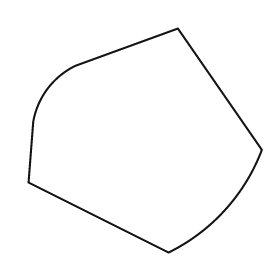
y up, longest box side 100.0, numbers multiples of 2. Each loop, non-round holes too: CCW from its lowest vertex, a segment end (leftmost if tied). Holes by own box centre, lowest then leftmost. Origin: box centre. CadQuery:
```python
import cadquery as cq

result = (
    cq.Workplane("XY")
    .moveTo(10.0, -48.0)
    .threePointArc((34.0, -30.0), (50.0, -4.0))
    .lineTo(14.0, 48.0)
    .lineTo(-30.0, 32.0)
    .threePointArc((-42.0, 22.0), (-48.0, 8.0))
    .lineTo(-50.0, -18.0)
    .close()
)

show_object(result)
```